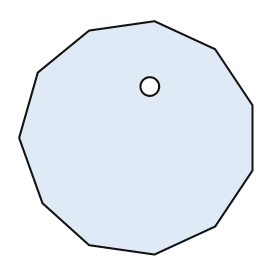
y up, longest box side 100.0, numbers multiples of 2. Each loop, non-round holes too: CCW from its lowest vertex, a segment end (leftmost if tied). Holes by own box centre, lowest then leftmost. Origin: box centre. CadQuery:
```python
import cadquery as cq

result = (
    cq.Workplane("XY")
    .moveTo(8.0, -50.0)
    .lineTo(34.0, -38.0)
    .lineTo(50.0, -14.0)
    .lineTo(50.0, 14.0)
    .lineTo(34.0, 38.0)
    .lineTo(8.0, 50.0)
    .lineTo(-20.0, 46.0)
    .lineTo(-42.0, 28.0)
    .lineTo(-50.0, 0.0)
    .lineTo(-40.0, -28.0)
    .lineTo(-20.0, -46.0)
    .close()
    .moveTo(6.0, 22.0)
    .circle(4.0)
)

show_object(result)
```